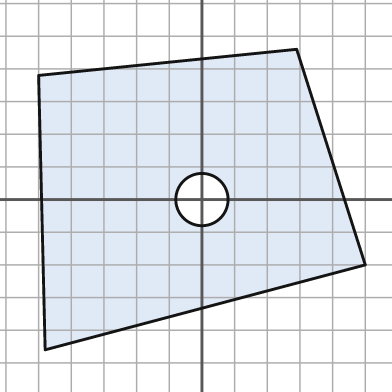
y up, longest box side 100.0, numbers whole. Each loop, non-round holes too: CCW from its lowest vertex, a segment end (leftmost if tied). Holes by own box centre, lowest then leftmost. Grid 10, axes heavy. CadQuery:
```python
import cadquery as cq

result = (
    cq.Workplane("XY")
    .moveTo(-48.0, -46.0)
    .lineTo(50.0, -20.0)
    .lineTo(29.0, 46.0)
    .lineTo(-50.0, 38.0)
    .close()
    .moveTo(0.0, 0.0)
    .circle(8.0)
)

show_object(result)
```